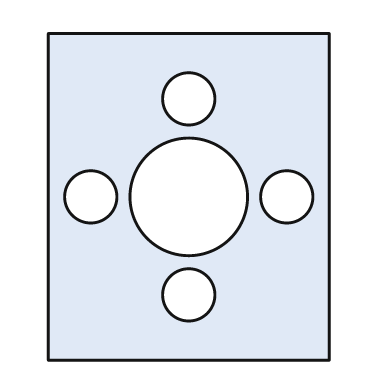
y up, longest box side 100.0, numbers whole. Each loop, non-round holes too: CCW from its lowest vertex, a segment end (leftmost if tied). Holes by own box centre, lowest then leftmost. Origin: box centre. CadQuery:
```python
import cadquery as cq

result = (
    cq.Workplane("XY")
    .moveTo(-43.0, -50.0)
    .lineTo(43.0, -50.0)
    .lineTo(43.0, 50.0)
    .lineTo(-43.0, 50.0)
    .close()
    .moveTo(0.0, -30.0)
    .circle(8.0)
    .moveTo(-30.0, 0.0)
    .circle(8.0)
    .moveTo(0.0, 0.0)
    .circle(18.0)
    .moveTo(30.0, 0.0)
    .circle(8.0)
    .moveTo(0.0, 30.0)
    .circle(8.0)
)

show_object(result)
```